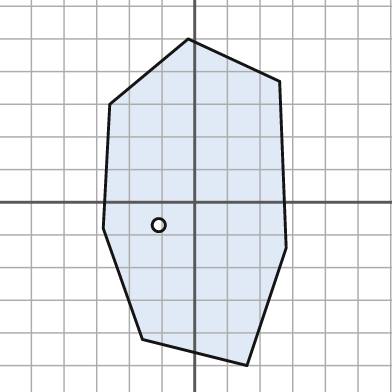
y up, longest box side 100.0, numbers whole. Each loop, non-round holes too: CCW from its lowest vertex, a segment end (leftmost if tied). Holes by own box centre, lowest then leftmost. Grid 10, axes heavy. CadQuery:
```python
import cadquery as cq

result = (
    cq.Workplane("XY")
    .moveTo(16.0, -50.0)
    .lineTo(28.0, -14.0)
    .lineTo(26.0, 37.0)
    .lineTo(-2.0, 50.0)
    .lineTo(-26.0, 30.0)
    .lineTo(-28.0, -8.0)
    .lineTo(-16.0, -42.0)
    .close()
    .moveTo(-11.0, -7.0)
    .circle(2.0)
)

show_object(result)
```